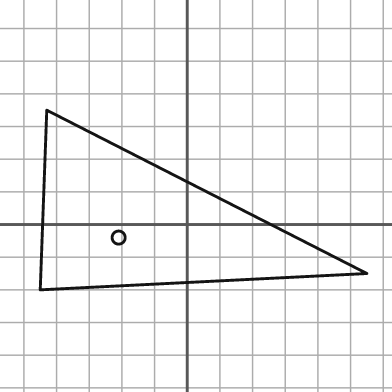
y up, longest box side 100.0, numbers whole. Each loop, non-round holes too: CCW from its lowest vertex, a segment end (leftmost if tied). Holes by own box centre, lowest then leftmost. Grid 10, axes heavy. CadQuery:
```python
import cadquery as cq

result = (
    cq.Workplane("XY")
    .moveTo(-45.0, -20.0)
    .lineTo(55.0, -15.0)
    .lineTo(-43.0, 35.0)
    .close()
    .moveTo(-21.0, -4.0)
    .circle(2.0)
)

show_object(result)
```